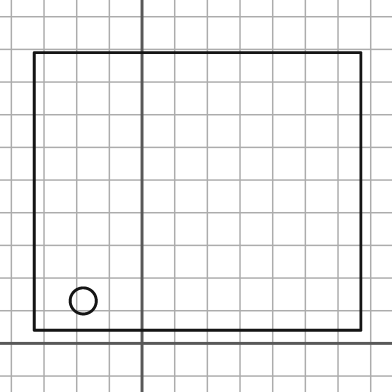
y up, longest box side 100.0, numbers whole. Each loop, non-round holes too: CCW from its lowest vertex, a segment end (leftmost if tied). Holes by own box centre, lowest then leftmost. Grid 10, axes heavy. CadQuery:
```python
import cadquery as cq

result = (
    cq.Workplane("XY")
    .moveTo(-33.0, 4.0)
    .lineTo(67.0, 4.0)
    .lineTo(67.0, 89.0)
    .lineTo(-33.0, 89.0)
    .close()
    .moveTo(-18.0, 13.0)
    .circle(4.0)
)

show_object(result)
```